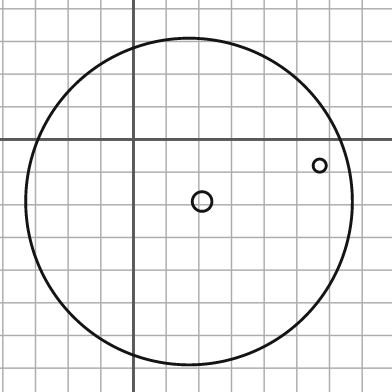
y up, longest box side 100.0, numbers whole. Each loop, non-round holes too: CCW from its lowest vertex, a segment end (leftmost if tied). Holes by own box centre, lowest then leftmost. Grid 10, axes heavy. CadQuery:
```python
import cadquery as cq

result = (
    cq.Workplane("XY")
    .moveTo(17.0, -19.0)
    .circle(50.0)
    .moveTo(21.0, -19.0)
    .circle(3.0)
    .moveTo(57.0, -8.0)
    .circle(2.0)
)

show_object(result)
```